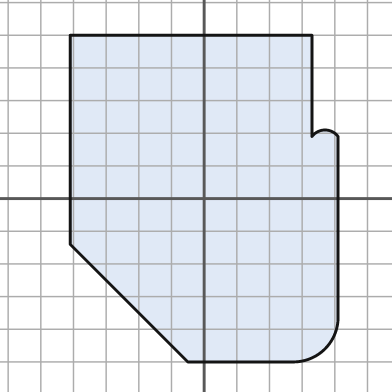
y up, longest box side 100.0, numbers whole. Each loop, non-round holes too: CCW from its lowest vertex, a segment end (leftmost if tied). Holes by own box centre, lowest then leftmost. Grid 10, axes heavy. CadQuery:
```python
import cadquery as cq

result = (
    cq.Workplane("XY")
    .moveTo(-5.0, -50.0)
    .lineTo(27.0, -50.0)
    .threePointArc((37.0, -46.0), (41.0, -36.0))
    .lineTo(41.0, 19.0)
    .threePointArc((37.0, 21.0), (33.0, 19.0))
    .lineTo(33.0, 50.0)
    .lineTo(-41.0, 50.0)
    .lineTo(-41.0, -14.0)
    .close()
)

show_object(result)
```